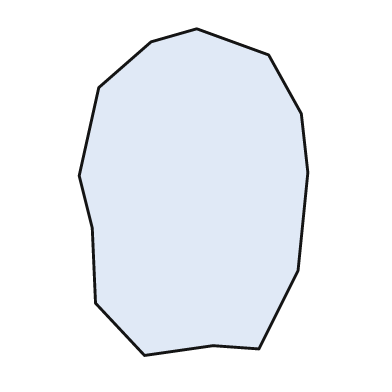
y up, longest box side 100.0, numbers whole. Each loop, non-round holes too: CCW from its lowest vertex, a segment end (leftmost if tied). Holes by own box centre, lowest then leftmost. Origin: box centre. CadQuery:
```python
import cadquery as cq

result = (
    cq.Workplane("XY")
    .moveTo(-15.0, -50.0)
    .lineTo(6.0, -47.0)
    .lineTo(20.0, -48.0)
    .lineTo(32.0, -24.0)
    .lineTo(35.0, 6.0)
    .lineTo(33.0, 24.0)
    .lineTo(23.0, 42.0)
    .lineTo(1.0, 50.0)
    .lineTo(-13.0, 46.0)
    .lineTo(-29.0, 32.0)
    .lineTo(-35.0, 5.0)
    .lineTo(-31.0, -11.0)
    .lineTo(-30.0, -34.0)
    .close()
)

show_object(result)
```